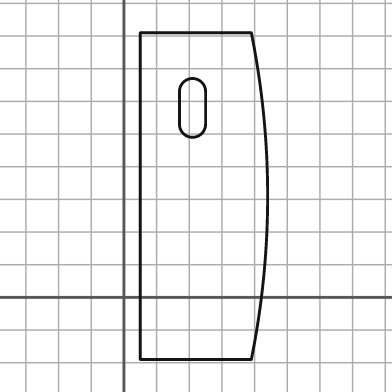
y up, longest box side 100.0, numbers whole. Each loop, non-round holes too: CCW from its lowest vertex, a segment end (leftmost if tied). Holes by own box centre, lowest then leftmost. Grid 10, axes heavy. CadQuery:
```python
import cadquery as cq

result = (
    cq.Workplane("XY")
    .moveTo(5.0, -19.0)
    .lineTo(39.0, -19.0)
    .threePointArc((44.0, 31.0), (39.0, 81.0))
    .lineTo(5.0, 81.0)
    .close()
    .moveTo(17.0, 53.0)
    .threePointArc((21.0, 49.0), (25.0, 53.0))
    .lineTo(25.0, 63.0)
    .threePointArc((21.0, 67.0), (17.0, 63.0))
    .close()
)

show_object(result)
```